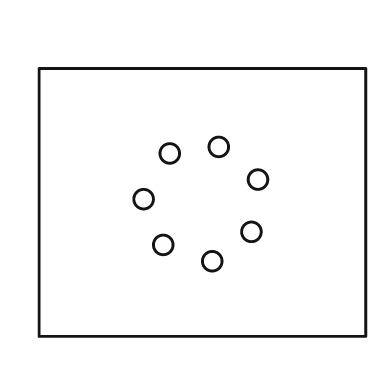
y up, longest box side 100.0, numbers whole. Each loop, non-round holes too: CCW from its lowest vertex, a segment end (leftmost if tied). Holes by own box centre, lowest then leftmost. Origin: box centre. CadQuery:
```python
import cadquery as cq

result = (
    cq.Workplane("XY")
    .moveTo(-50.0, -41.0)
    .lineTo(50.0, -41.0)
    .lineTo(50.0, 41.0)
    .lineTo(-50.0, 41.0)
    .close()
    .moveTo(3.0, -18.0)
    .circle(3.0)
    .moveTo(-12.0, -13.0)
    .circle(3.0)
    .moveTo(15.0, -9.0)
    .circle(3.0)
    .moveTo(-18.0, 1.0)
    .circle(3.0)
    .moveTo(17.0, 7.0)
    .circle(3.0)
    .moveTo(-10.0, 15.0)
    .circle(3.0)
    .moveTo(5.0, 17.0)
    .circle(3.0)
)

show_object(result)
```